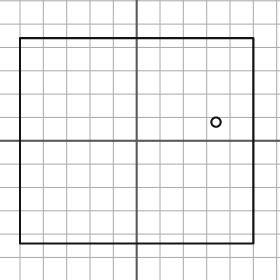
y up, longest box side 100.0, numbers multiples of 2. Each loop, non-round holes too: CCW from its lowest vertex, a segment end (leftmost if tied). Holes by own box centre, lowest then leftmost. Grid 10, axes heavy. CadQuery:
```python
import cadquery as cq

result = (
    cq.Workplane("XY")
    .moveTo(-50.0, -44.0)
    .lineTo(50.0, -44.0)
    .lineTo(50.0, 44.0)
    .lineTo(-50.0, 44.0)
    .close()
    .moveTo(34.0, 8.0)
    .circle(2.0)
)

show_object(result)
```